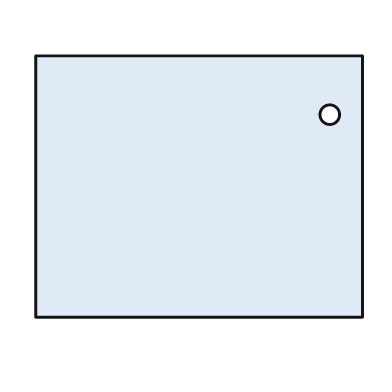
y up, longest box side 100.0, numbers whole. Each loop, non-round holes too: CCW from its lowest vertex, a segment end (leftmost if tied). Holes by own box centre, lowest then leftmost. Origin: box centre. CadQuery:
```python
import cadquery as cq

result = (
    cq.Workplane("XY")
    .moveTo(-50.0, -40.0)
    .lineTo(50.0, -40.0)
    .lineTo(50.0, 40.0)
    .lineTo(-50.0, 40.0)
    .close()
    .moveTo(40.0, 22.0)
    .circle(3.0)
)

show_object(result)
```